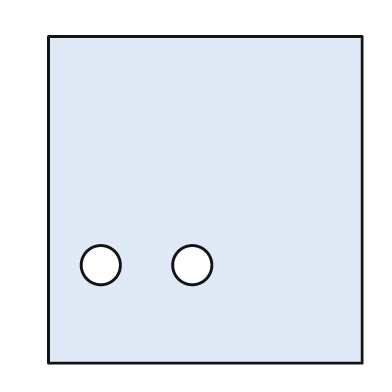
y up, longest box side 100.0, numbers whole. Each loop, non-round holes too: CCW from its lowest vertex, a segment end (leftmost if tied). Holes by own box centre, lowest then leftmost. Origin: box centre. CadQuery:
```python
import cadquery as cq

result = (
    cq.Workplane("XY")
    .moveTo(-48.0, -50.0)
    .lineTo(48.0, -50.0)
    .lineTo(48.0, 50.0)
    .lineTo(-48.0, 50.0)
    .close()
    .moveTo(-32.0, -20.0)
    .circle(6.0)
    .moveTo(-4.0, -20.0)
    .circle(6.0)
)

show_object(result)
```